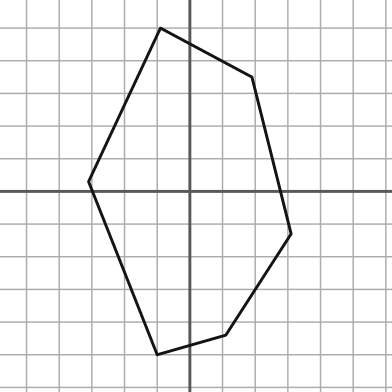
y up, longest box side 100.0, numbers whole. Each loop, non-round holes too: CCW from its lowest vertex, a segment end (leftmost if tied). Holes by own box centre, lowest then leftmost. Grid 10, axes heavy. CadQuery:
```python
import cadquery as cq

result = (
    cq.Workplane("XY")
    .moveTo(-10.0, -50.0)
    .lineTo(11.0, -44.0)
    .lineTo(31.0, -13.0)
    .lineTo(19.0, 35.0)
    .lineTo(-9.0, 50.0)
    .lineTo(-31.0, 3.0)
    .close()
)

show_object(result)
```